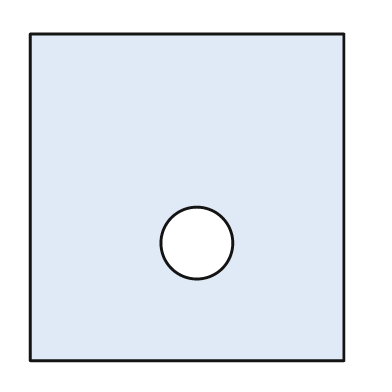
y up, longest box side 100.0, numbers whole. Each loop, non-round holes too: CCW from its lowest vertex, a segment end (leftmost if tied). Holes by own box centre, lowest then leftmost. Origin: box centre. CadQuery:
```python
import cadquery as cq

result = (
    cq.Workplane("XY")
    .moveTo(-48.0, -50.0)
    .lineTo(48.0, -50.0)
    .lineTo(48.0, 50.0)
    .lineTo(-48.0, 50.0)
    .close()
    .moveTo(3.0, -14.0)
    .circle(11.0)
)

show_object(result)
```